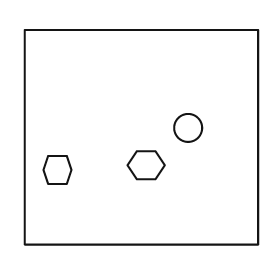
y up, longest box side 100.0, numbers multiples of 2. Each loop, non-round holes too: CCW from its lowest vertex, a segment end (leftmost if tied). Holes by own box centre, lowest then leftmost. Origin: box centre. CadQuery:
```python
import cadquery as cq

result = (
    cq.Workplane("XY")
    .moveTo(-50.0, -46.0)
    .lineTo(50.0, -46.0)
    .lineTo(50.0, 46.0)
    .lineTo(-50.0, 46.0)
    .close()
    .moveTo(-40.0, -20.0)
    .lineTo(-32.0, -20.0)
    .lineTo(-30.0, -14.0)
    .lineTo(-32.0, -8.0)
    .lineTo(-40.0, -8.0)
    .lineTo(-42.0, -14.0)
    .close()
    .moveTo(-2.0, -18.0)
    .lineTo(6.0, -18.0)
    .lineTo(10.0, -12.0)
    .lineTo(6.0, -6.0)
    .lineTo(-2.0, -6.0)
    .lineTo(-6.0, -12.0)
    .close()
    .moveTo(20.0, 4.0)
    .circle(6.0)
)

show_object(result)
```